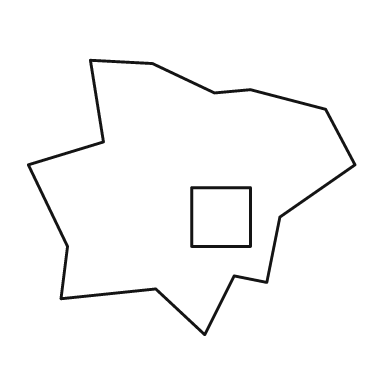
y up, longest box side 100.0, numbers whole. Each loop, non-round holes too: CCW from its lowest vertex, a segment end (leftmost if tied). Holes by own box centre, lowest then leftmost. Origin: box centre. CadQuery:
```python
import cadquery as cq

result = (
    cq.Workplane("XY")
    .moveTo(4.0, -42.0)
    .lineTo(13.0, -24.0)
    .lineTo(23.0, -26.0)
    .lineTo(27.0, -6.0)
    .lineTo(50.0, 10.0)
    .lineTo(41.0, 27.0)
    .lineTo(18.0, 33.0)
    .lineTo(7.0, 32.0)
    .lineTo(-12.0, 41.0)
    .lineTo(-31.0, 42.0)
    .lineTo(-27.0, 17.0)
    .lineTo(-50.0, 10.0)
    .lineTo(-38.0, -15.0)
    .lineTo(-40.0, -31.0)
    .lineTo(-11.0, -28.0)
    .close()
    .moveTo(0.0, -15.0)
    .lineTo(18.0, -15.0)
    .lineTo(18.0, 3.0)
    .lineTo(0.0, 3.0)
    .close()
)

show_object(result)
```